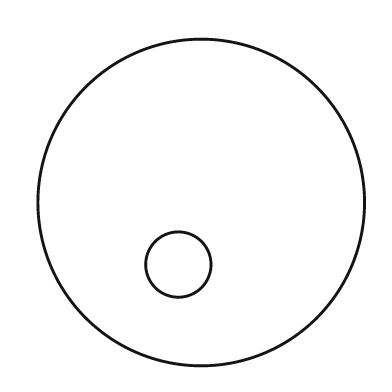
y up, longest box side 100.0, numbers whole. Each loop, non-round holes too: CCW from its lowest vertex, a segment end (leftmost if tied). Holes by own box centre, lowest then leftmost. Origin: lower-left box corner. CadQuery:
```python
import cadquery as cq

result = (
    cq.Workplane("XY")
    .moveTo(50.0, 50.0)
    .circle(50.0)
    .moveTo(43.0, 31.0)
    .circle(10.0)
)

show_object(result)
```